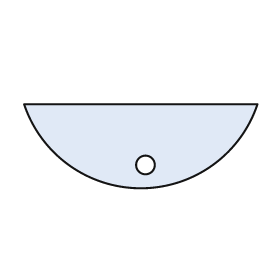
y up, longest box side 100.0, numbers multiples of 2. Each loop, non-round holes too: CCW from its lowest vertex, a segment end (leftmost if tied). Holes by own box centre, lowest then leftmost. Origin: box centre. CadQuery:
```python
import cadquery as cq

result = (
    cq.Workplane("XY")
    .moveTo(-50.0, 18.0)
    .threePointArc((0.0, -18.0), (50.0, 18.0))
    .close()
    .moveTo(2.0, -8.0)
    .circle(4.0)
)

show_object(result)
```